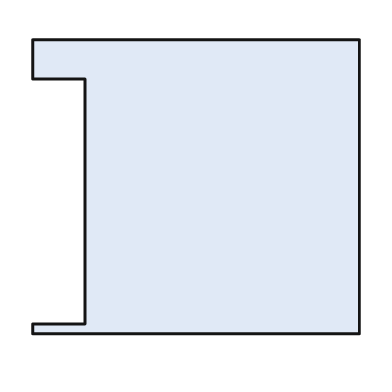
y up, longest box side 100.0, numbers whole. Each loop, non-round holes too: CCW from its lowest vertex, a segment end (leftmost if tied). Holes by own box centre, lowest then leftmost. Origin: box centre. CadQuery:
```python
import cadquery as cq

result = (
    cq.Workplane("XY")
    .moveTo(-50.0, -45.0)
    .lineTo(50.0, -45.0)
    .lineTo(50.0, 45.0)
    .lineTo(-50.0, 45.0)
    .lineTo(-50.0, 33.0)
    .lineTo(-34.0, 33.0)
    .lineTo(-34.0, -42.0)
    .lineTo(-50.0, -42.0)
    .close()
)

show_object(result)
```